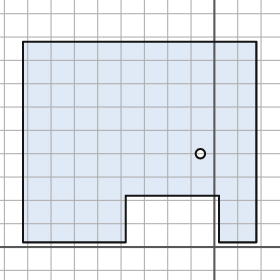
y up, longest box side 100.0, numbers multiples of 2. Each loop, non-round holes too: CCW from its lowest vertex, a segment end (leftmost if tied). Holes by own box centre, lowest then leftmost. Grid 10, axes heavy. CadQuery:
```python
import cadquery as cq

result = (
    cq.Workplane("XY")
    .moveTo(-82.0, 2.0)
    .lineTo(-38.0, 2.0)
    .lineTo(-38.0, 22.0)
    .lineTo(2.0, 22.0)
    .lineTo(2.0, 2.0)
    .lineTo(18.0, 2.0)
    .lineTo(18.0, 88.0)
    .lineTo(-82.0, 88.0)
    .close()
    .moveTo(-6.0, 40.0)
    .circle(2.0)
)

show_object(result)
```